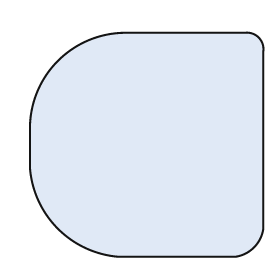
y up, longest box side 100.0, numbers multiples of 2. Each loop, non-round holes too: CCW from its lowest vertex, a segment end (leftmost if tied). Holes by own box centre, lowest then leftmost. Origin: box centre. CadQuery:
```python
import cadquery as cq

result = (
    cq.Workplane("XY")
    .moveTo(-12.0, -48.0)
    .lineTo(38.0, -48.0)
    .threePointArc((46.0, -44.0), (50.0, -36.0))
    .lineTo(50.0, 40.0)
    .threePointArc((48.0, 46.0), (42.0, 48.0))
    .lineTo(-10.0, 48.0)
    .threePointArc((-38.0, 36.0), (-50.0, 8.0))
    .lineTo(-50.0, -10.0)
    .threePointArc((-38.0, -36.0), (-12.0, -48.0))
    .close()
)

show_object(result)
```